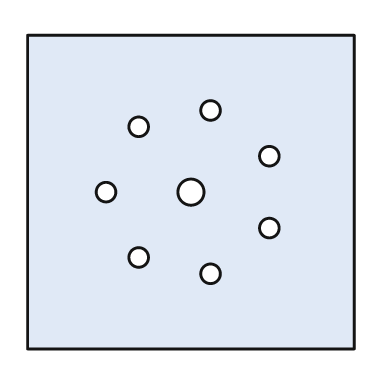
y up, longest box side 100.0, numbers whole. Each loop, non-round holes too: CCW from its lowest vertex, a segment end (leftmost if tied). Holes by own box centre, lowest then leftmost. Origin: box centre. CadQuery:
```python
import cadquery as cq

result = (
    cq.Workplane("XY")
    .moveTo(-50.0, -48.0)
    .lineTo(50.0, -48.0)
    .lineTo(50.0, 48.0)
    .lineTo(-50.0, 48.0)
    .close()
    .moveTo(6.0, -25.0)
    .circle(3.0)
    .moveTo(-16.0, -20.0)
    .circle(3.0)
    .moveTo(24.0, -11.0)
    .circle(3.0)
    .moveTo(-26.0, 0.0)
    .circle(3.0)
    .moveTo(0.0, 0.0)
    .circle(4.0)
    .moveTo(24.0, 11.0)
    .circle(3.0)
    .moveTo(-16.0, 20.0)
    .circle(3.0)
    .moveTo(6.0, 25.0)
    .circle(3.0)
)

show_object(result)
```